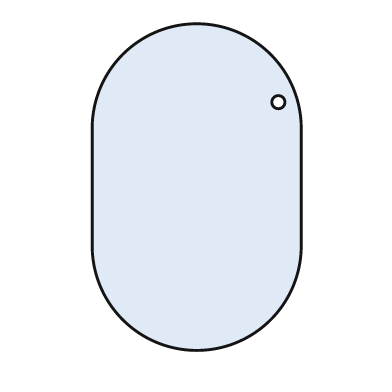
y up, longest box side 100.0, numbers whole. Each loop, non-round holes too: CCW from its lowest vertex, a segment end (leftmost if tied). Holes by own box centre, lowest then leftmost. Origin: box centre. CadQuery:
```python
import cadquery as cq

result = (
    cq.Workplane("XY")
    .moveTo(-32.0, -18.0)
    .threePointArc((0.0, -50.0), (32.0, -18.0))
    .lineTo(32.0, 18.0)
    .threePointArc((0.0, 50.0), (-32.0, 18.0))
    .close()
    .moveTo(25.0, 26.0)
    .circle(2.0)
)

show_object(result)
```